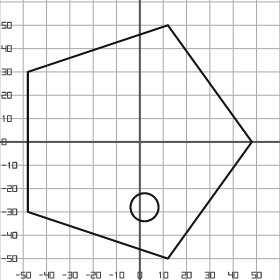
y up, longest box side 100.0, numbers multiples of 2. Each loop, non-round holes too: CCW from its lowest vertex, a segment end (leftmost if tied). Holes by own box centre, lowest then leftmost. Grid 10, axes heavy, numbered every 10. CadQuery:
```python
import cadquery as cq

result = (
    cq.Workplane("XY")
    .moveTo(12.0, -50.0)
    .lineTo(48.0, 0.0)
    .lineTo(12.0, 50.0)
    .lineTo(-48.0, 30.0)
    .lineTo(-48.0, -30.0)
    .close()
    .moveTo(2.0, -28.0)
    .circle(6.0)
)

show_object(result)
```